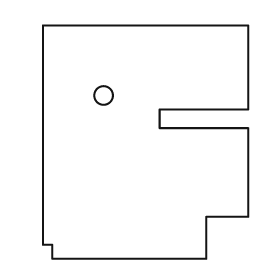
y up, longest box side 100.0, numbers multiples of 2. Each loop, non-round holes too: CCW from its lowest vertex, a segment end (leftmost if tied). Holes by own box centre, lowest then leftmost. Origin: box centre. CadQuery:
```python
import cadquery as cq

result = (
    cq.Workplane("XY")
    .moveTo(-40.0, -50.0)
    .lineTo(26.0, -50.0)
    .lineTo(26.0, -32.0)
    .lineTo(44.0, -32.0)
    .lineTo(44.0, 6.0)
    .lineTo(6.0, 6.0)
    .lineTo(6.0, 14.0)
    .lineTo(44.0, 14.0)
    .lineTo(44.0, 50.0)
    .lineTo(-44.0, 50.0)
    .lineTo(-44.0, -44.0)
    .lineTo(-40.0, -44.0)
    .close()
    .moveTo(-18.0, 20.0)
    .circle(4.0)
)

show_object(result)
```